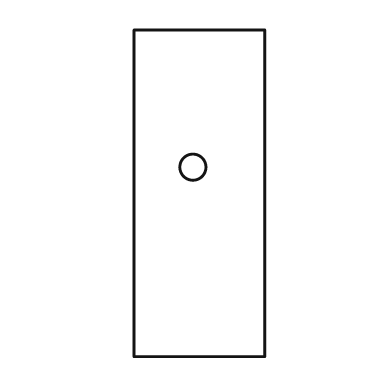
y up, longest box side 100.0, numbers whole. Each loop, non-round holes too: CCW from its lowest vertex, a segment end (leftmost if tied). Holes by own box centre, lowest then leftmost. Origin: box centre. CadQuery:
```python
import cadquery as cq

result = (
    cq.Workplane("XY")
    .moveTo(-20.0, -50.0)
    .lineTo(20.0, -50.0)
    .lineTo(20.0, 50.0)
    .lineTo(-20.0, 50.0)
    .close()
    .moveTo(-2.0, 8.0)
    .circle(4.0)
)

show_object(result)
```